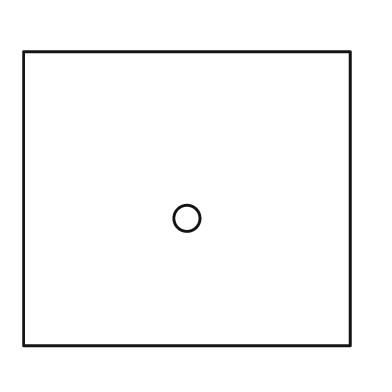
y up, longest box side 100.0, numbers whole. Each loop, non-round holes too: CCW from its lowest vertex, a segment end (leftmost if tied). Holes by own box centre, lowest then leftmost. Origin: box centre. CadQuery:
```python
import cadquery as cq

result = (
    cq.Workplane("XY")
    .moveTo(-50.0, -45.0)
    .lineTo(50.0, -45.0)
    .lineTo(50.0, 45.0)
    .lineTo(-50.0, 45.0)
    .close()
    .moveTo(0.0, -6.0)
    .circle(4.0)
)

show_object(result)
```